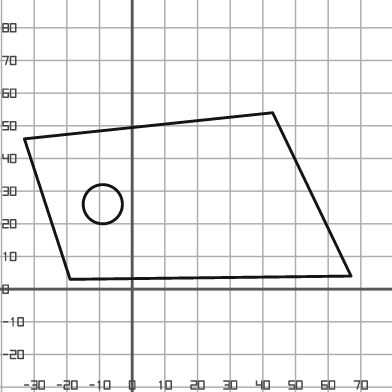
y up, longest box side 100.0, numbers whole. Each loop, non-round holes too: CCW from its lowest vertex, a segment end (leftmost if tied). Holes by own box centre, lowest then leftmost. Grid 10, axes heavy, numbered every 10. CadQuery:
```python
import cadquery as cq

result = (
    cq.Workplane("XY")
    .moveTo(-19.0, 3.0)
    .lineTo(67.0, 4.0)
    .lineTo(43.0, 54.0)
    .lineTo(-33.0, 46.0)
    .close()
    .moveTo(-9.0, 26.0)
    .circle(6.0)
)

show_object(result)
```